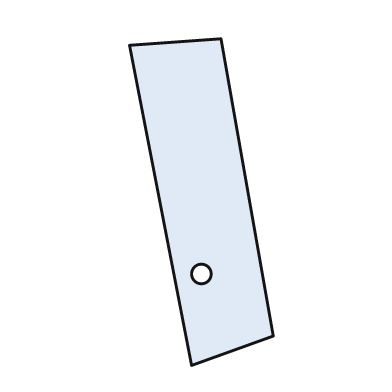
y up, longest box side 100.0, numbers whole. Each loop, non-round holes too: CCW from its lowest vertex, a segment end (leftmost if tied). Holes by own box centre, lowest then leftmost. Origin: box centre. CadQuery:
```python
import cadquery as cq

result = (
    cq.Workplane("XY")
    .moveTo(-3.0, -50.0)
    .lineTo(22.0, -41.0)
    .lineTo(6.0, 50.0)
    .lineTo(-22.0, 48.0)
    .close()
    .moveTo(0.0, -22.0)
    .circle(3.0)
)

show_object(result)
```